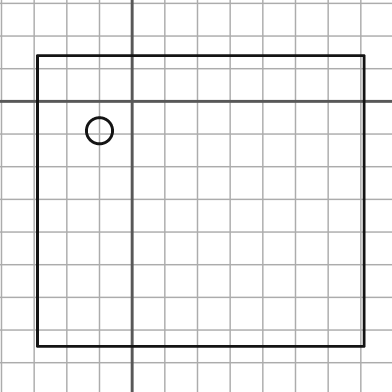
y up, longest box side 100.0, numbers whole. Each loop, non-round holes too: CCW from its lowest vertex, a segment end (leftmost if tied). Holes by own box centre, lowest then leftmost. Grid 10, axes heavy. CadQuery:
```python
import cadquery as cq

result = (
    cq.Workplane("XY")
    .moveTo(-29.0, -75.0)
    .lineTo(71.0, -75.0)
    .lineTo(71.0, 14.0)
    .lineTo(-29.0, 14.0)
    .close()
    .moveTo(-10.0, -9.0)
    .circle(4.0)
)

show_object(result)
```